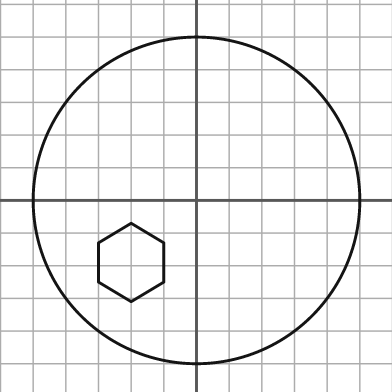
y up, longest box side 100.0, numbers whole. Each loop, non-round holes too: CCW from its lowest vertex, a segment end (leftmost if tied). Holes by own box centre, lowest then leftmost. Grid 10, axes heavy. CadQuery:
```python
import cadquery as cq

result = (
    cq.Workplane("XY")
    .moveTo(0.0, 0.0)
    .circle(50.0)
    .moveTo(-20.0, -31.0)
    .lineTo(-10.0, -25.0)
    .lineTo(-10.0, -13.0)
    .lineTo(-20.0, -7.0)
    .lineTo(-30.0, -13.0)
    .lineTo(-30.0, -25.0)
    .close()
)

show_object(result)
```